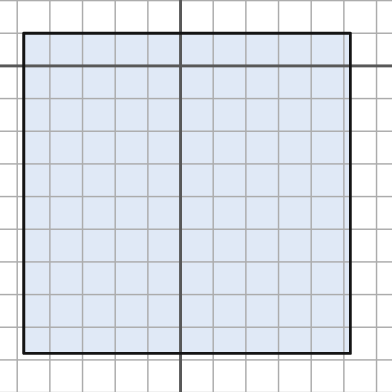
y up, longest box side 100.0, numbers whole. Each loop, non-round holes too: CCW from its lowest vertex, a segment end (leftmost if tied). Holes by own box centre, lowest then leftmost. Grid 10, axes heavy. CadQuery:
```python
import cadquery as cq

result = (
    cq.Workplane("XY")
    .moveTo(-48.0, -88.0)
    .lineTo(52.0, -88.0)
    .lineTo(52.0, 10.0)
    .lineTo(-48.0, 10.0)
    .close()
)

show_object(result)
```